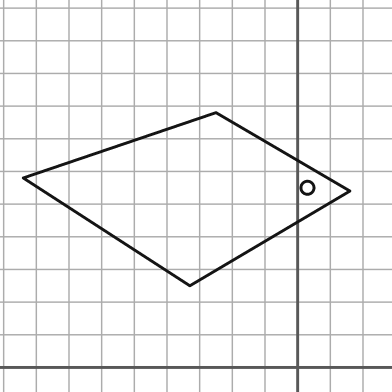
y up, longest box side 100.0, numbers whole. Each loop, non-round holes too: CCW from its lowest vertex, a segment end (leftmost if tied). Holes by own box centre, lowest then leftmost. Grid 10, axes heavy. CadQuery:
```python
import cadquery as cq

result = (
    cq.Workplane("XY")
    .moveTo(-33.0, 25.0)
    .lineTo(16.0, 54.0)
    .lineTo(-25.0, 78.0)
    .lineTo(-84.0, 58.0)
    .close()
    .moveTo(3.0, 55.0)
    .circle(2.0)
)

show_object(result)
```